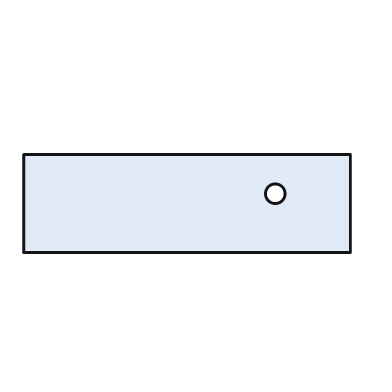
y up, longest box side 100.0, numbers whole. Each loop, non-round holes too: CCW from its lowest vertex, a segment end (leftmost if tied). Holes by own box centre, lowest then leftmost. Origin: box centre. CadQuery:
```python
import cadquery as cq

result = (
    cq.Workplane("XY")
    .moveTo(-50.0, -15.0)
    .lineTo(50.0, -15.0)
    .lineTo(50.0, 15.0)
    .lineTo(-50.0, 15.0)
    .close()
    .moveTo(27.0, 3.0)
    .circle(3.0)
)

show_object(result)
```